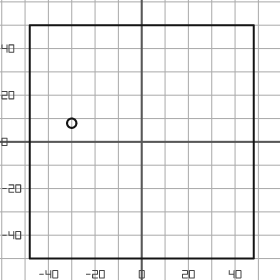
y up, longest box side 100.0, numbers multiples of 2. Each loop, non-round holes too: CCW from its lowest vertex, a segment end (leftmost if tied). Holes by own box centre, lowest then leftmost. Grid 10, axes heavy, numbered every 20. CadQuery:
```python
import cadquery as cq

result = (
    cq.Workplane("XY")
    .moveTo(-48.0, -50.0)
    .lineTo(48.0, -50.0)
    .lineTo(48.0, 50.0)
    .lineTo(-48.0, 50.0)
    .close()
    .moveTo(-30.0, 8.0)
    .circle(2.0)
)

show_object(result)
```